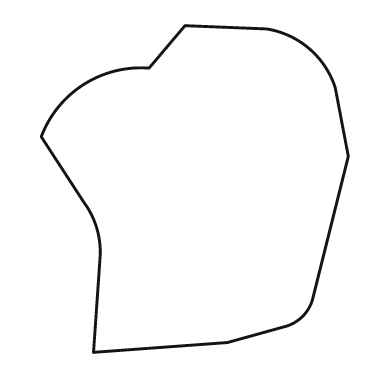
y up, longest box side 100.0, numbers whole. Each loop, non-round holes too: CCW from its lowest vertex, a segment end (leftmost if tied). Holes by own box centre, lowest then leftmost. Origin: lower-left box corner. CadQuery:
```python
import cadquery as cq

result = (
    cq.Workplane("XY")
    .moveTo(16.0, 0.0)
    .lineTo(57.0, 3.0)
    .lineTo(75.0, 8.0)
    .threePointArc((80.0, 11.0), (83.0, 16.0))
    .lineTo(94.0, 60.0)
    .lineTo(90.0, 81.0)
    .threePointArc((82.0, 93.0), (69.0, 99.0))
    .lineTo(44.0, 100.0)
    .lineTo(33.0, 87.0)
    .threePointArc((13.0, 82.0), (0.0, 66.0))
    .lineTo(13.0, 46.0)
    .threePointArc((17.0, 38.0), (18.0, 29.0))
    .close()
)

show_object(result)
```